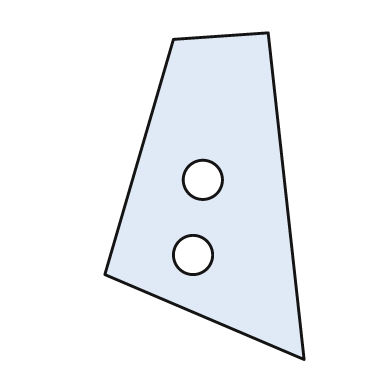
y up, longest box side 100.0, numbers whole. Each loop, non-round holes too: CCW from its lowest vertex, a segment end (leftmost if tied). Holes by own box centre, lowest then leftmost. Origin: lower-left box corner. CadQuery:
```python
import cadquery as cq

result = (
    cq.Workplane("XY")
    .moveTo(61.0, 0.0)
    .lineTo(50.0, 100.0)
    .lineTo(21.0, 98.0)
    .lineTo(0.0, 26.0)
    .close()
    .moveTo(27.0, 32.0)
    .circle(6.0)
    .moveTo(30.0, 55.0)
    .circle(6.0)
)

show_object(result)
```